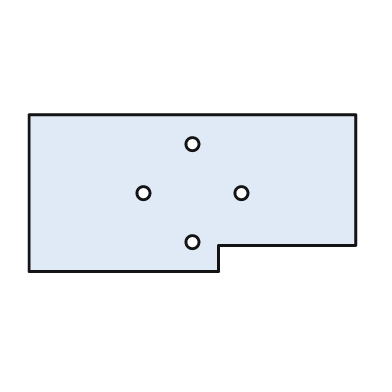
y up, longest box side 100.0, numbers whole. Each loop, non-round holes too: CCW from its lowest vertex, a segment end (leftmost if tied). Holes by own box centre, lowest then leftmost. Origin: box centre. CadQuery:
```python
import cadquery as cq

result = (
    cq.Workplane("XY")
    .moveTo(-50.0, -24.0)
    .lineTo(8.0, -24.0)
    .lineTo(8.0, -16.0)
    .lineTo(50.0, -16.0)
    .lineTo(50.0, 24.0)
    .lineTo(-50.0, 24.0)
    .close()
    .moveTo(0.0, -15.0)
    .circle(2.0)
    .moveTo(-15.0, 0.0)
    .circle(2.0)
    .moveTo(15.0, 0.0)
    .circle(2.0)
    .moveTo(0.0, 15.0)
    .circle(2.0)
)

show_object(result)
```